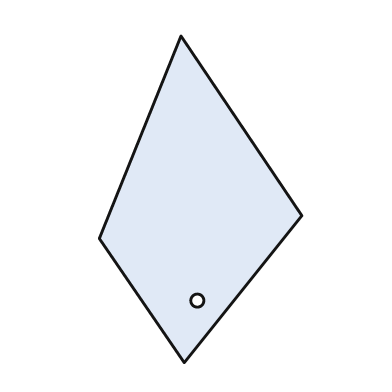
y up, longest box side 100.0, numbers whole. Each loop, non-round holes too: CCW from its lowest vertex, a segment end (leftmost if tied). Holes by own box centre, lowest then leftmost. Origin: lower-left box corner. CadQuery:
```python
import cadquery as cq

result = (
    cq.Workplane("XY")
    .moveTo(26.0, 0.0)
    .lineTo(62.0, 45.0)
    .lineTo(25.0, 100.0)
    .lineTo(0.0, 38.0)
    .close()
    .moveTo(30.0, 19.0)
    .circle(2.0)
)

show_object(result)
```